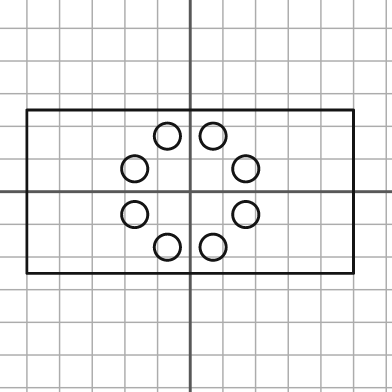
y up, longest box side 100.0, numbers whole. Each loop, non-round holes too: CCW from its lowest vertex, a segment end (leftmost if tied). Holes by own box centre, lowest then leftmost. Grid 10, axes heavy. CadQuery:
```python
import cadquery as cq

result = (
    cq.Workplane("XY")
    .moveTo(-50.0, -25.0)
    .lineTo(50.0, -25.0)
    .lineTo(50.0, 25.0)
    .lineTo(-50.0, 25.0)
    .close()
    .moveTo(-7.0, -17.0)
    .circle(4.0)
    .moveTo(7.0, -17.0)
    .circle(4.0)
    .moveTo(-17.0, -7.0)
    .circle(4.0)
    .moveTo(17.0, -7.0)
    .circle(4.0)
    .moveTo(-17.0, 7.0)
    .circle(4.0)
    .moveTo(17.0, 7.0)
    .circle(4.0)
    .moveTo(-7.0, 17.0)
    .circle(4.0)
    .moveTo(7.0, 17.0)
    .circle(4.0)
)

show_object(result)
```